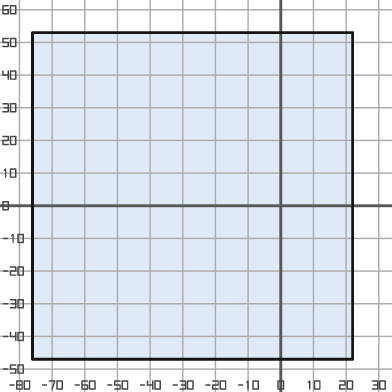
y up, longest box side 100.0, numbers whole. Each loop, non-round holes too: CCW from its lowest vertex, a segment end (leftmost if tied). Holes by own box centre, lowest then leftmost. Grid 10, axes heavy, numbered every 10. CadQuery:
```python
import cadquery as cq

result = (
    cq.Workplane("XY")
    .moveTo(-76.0, -47.0)
    .lineTo(22.0, -47.0)
    .lineTo(22.0, 53.0)
    .lineTo(-76.0, 53.0)
    .close()
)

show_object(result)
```